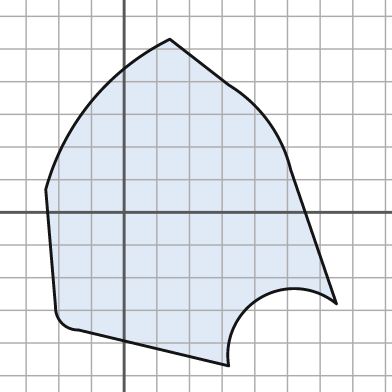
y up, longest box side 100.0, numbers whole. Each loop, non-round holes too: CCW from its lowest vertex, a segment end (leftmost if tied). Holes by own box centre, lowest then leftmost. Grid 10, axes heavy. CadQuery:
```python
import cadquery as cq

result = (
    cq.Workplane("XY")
    .moveTo(32.0, -47.0)
    .threePointArc((42.0, -26.0), (65.0, -28.0))
    .lineTo(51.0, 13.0)
    .threePointArc((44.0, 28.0), (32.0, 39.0))
    .lineTo(14.0, 53.0)
    .threePointArc((-10.0, 34.0), (-24.0, 7.0))
    .lineTo(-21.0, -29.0)
    .threePointArc((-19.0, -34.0), (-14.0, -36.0))
    .close()
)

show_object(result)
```